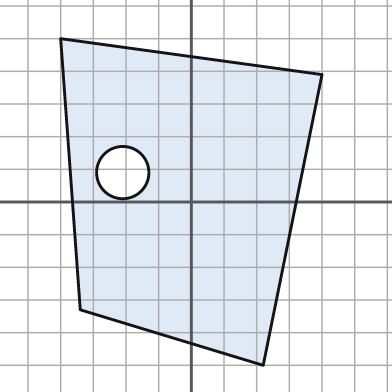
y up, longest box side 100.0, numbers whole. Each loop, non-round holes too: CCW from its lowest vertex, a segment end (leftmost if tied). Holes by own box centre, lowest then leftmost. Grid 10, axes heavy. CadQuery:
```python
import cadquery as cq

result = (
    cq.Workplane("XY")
    .moveTo(22.0, -50.0)
    .lineTo(40.0, 39.0)
    .lineTo(-40.0, 50.0)
    .lineTo(-34.0, -33.0)
    .close()
    .moveTo(-21.0, 9.0)
    .circle(8.0)
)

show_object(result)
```